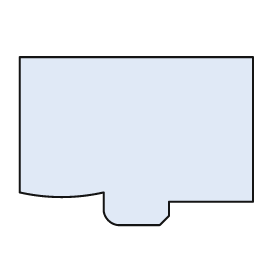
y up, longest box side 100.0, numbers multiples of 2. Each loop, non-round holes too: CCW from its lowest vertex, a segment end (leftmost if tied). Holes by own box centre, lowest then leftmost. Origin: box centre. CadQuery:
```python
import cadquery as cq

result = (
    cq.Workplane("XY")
    .moveTo(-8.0, -36.0)
    .lineTo(10.0, -36.0)
    .lineTo(14.0, -32.0)
    .lineTo(14.0, -26.0)
    .lineTo(50.0, -26.0)
    .lineTo(50.0, 36.0)
    .lineTo(-50.0, 36.0)
    .lineTo(-50.0, -22.0)
    .threePointArc((-32.0, -24.0), (-14.0, -22.0))
    .lineTo(-14.0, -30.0)
    .threePointArc((-12.0, -34.0), (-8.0, -36.0))
    .close()
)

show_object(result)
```